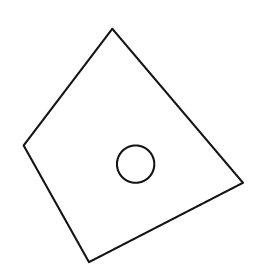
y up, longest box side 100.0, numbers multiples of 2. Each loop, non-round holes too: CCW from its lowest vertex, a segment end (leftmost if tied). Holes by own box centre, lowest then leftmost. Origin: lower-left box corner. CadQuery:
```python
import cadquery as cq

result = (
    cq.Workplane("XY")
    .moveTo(28.0, 0.0)
    .lineTo(94.0, 34.0)
    .lineTo(38.0, 100.0)
    .lineTo(0.0, 50.0)
    .close()
    .moveTo(48.0, 42.0)
    .circle(8.0)
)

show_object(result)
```